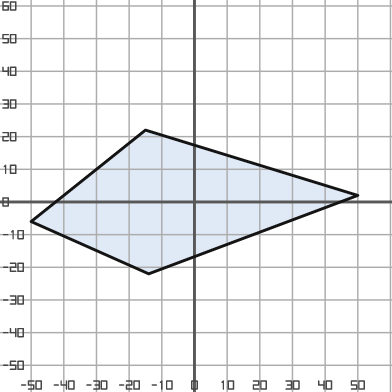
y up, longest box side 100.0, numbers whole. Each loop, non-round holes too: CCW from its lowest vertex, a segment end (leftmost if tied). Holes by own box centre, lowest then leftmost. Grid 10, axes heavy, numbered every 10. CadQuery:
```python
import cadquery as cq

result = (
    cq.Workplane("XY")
    .moveTo(-14.0, -22.0)
    .lineTo(50.0, 2.0)
    .lineTo(-15.0, 22.0)
    .lineTo(-50.0, -6.0)
    .close()
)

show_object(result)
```